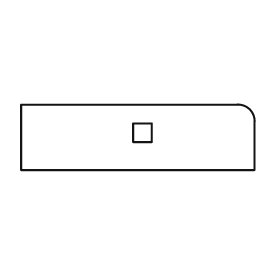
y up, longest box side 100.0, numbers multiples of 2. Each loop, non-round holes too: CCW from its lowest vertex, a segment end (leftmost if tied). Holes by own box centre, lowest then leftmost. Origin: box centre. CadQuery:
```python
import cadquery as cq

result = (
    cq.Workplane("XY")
    .moveTo(-50.0, -14.0)
    .lineTo(50.0, -14.0)
    .lineTo(50.0, 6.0)
    .threePointArc((48.0, 12.0), (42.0, 14.0))
    .lineTo(-50.0, 14.0)
    .close()
    .moveTo(-2.0, -2.0)
    .lineTo(6.0, -2.0)
    .lineTo(6.0, 6.0)
    .lineTo(-2.0, 6.0)
    .close()
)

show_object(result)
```